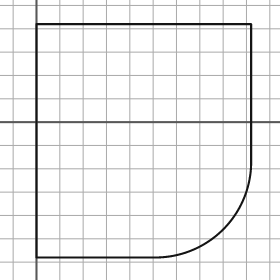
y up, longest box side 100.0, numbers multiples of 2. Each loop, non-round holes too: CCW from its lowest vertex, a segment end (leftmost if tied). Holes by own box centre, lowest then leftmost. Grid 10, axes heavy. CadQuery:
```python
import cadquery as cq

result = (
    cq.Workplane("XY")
    .moveTo(0.0, -58.0)
    .lineTo(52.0, -58.0)
    .threePointArc((80.0, -46.0), (92.0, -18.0))
    .lineTo(92.0, 42.0)
    .lineTo(0.0, 42.0)
    .close()
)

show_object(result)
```